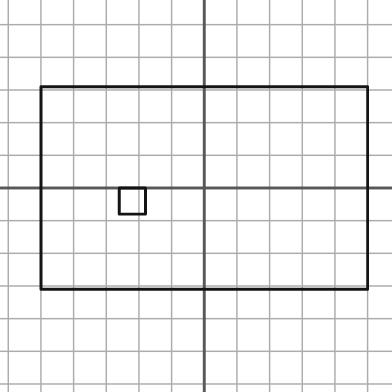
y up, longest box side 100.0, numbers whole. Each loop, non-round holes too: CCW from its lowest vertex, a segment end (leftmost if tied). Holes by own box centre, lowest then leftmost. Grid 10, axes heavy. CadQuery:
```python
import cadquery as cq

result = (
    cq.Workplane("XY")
    .moveTo(-50.0, -31.0)
    .lineTo(50.0, -31.0)
    .lineTo(50.0, 31.0)
    .lineTo(-50.0, 31.0)
    .close()
    .moveTo(-26.0, -8.0)
    .lineTo(-18.0, -8.0)
    .lineTo(-18.0, 0.0)
    .lineTo(-26.0, 0.0)
    .close()
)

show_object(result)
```